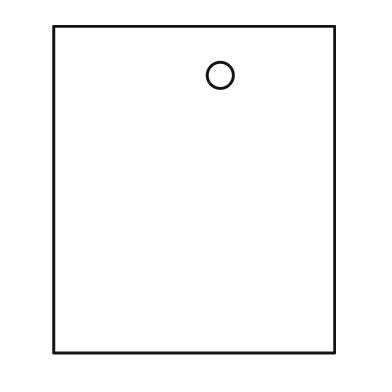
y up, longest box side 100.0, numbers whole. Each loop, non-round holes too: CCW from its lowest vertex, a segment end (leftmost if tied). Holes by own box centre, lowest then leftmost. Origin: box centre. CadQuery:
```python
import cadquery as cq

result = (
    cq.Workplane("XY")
    .moveTo(-43.0, -50.0)
    .lineTo(43.0, -50.0)
    .lineTo(43.0, 50.0)
    .lineTo(-43.0, 50.0)
    .close()
    .moveTo(8.0, 35.0)
    .circle(4.0)
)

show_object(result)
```